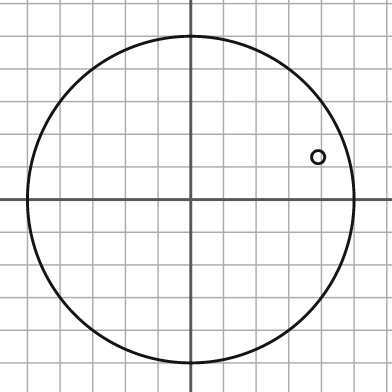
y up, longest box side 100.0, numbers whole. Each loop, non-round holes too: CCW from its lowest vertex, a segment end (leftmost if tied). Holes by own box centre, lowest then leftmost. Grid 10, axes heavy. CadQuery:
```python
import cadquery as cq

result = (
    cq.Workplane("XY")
    .moveTo(0.0, 0.0)
    .circle(50.0)
    .moveTo(39.0, 13.0)
    .circle(2.0)
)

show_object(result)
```